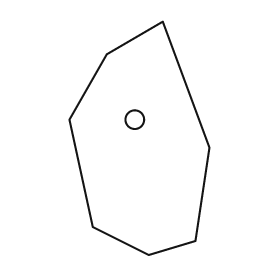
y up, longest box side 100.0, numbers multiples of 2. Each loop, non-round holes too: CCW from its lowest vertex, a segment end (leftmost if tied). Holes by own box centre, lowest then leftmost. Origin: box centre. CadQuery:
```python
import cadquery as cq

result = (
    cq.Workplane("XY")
    .moveTo(4.0, -50.0)
    .lineTo(24.0, -44.0)
    .lineTo(30.0, -4.0)
    .lineTo(10.0, 50.0)
    .lineTo(-14.0, 36.0)
    .lineTo(-30.0, 8.0)
    .lineTo(-20.0, -38.0)
    .close()
    .moveTo(-2.0, 8.0)
    .circle(4.0)
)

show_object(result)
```